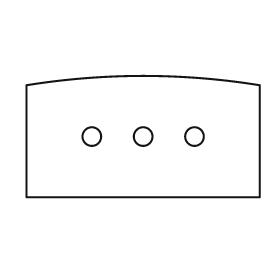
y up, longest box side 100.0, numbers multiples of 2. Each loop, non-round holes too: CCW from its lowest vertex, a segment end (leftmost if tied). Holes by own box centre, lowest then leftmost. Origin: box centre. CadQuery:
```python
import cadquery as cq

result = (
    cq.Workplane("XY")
    .moveTo(-50.0, -26.0)
    .lineTo(50.0, -26.0)
    .lineTo(50.0, 22.0)
    .threePointArc((0.0, 26.0), (-50.0, 22.0))
    .close()
    .moveTo(-22.0, 0.0)
    .circle(4.0)
    .moveTo(0.0, 0.0)
    .circle(4.0)
    .moveTo(22.0, 0.0)
    .circle(4.0)
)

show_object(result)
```